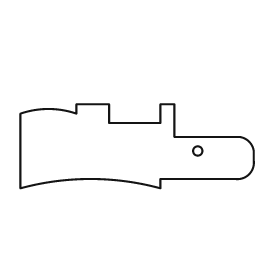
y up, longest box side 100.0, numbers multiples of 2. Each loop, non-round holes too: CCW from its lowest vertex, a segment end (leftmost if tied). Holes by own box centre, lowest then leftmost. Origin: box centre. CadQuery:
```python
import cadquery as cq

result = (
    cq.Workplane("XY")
    .moveTo(-50.0, -18.0)
    .threePointArc((-20.0, -14.0), (10.0, -18.0))
    .lineTo(10.0, -14.0)
    .lineTo(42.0, -14.0)
    .threePointArc((48.0, -12.0), (50.0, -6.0))
    .lineTo(50.0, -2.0)
    .threePointArc((48.0, 2.0), (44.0, 4.0))
    .lineTo(16.0, 4.0)
    .lineTo(16.0, 18.0)
    .lineTo(10.0, 18.0)
    .lineTo(10.0, 10.0)
    .lineTo(-12.0, 10.0)
    .lineTo(-12.0, 18.0)
    .lineTo(-26.0, 18.0)
    .lineTo(-26.0, 14.0)
    .threePointArc((-38.0, 16.0), (-50.0, 14.0))
    .close()
    .moveTo(26.0, -2.0)
    .circle(2.0)
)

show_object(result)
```